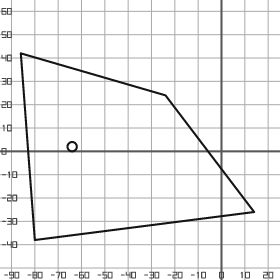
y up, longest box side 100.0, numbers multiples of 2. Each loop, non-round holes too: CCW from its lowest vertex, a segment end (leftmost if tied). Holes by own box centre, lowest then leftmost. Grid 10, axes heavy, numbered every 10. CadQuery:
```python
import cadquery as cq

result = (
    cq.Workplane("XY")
    .moveTo(-80.0, -38.0)
    .lineTo(14.0, -26.0)
    .lineTo(-24.0, 24.0)
    .lineTo(-86.0, 42.0)
    .close()
    .moveTo(-64.0, 2.0)
    .circle(2.0)
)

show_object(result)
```